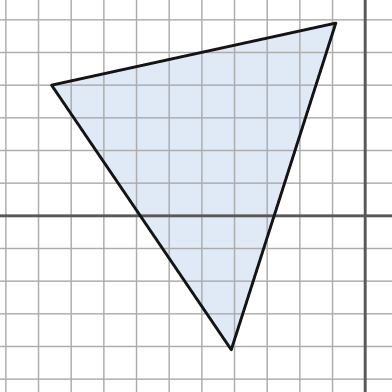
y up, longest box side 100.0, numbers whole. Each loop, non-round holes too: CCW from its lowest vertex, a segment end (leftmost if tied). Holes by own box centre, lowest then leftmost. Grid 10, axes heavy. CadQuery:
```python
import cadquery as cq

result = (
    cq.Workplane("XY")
    .moveTo(-41.0, -41.0)
    .lineTo(-9.0, 59.0)
    .lineTo(-96.0, 40.0)
    .close()
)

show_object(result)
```